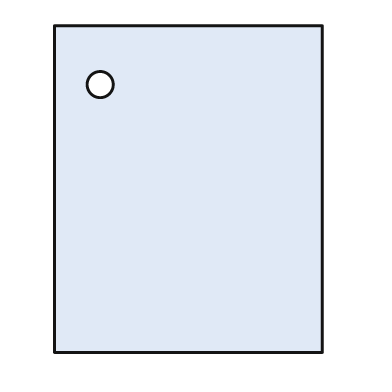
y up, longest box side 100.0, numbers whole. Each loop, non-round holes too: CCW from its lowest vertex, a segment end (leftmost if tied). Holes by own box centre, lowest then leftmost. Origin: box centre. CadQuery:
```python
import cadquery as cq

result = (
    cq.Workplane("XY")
    .moveTo(-41.0, -50.0)
    .lineTo(41.0, -50.0)
    .lineTo(41.0, 50.0)
    .lineTo(-41.0, 50.0)
    .close()
    .moveTo(-27.0, 32.0)
    .circle(4.0)
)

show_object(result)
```